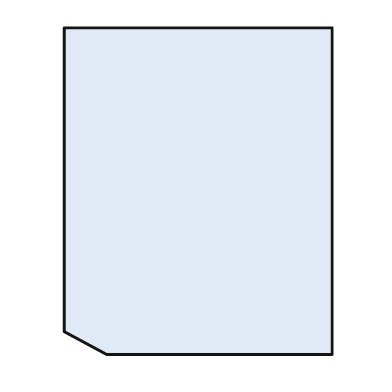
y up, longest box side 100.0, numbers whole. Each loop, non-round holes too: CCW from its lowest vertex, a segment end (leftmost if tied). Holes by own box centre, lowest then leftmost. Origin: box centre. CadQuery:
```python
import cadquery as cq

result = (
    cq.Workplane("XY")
    .moveTo(-28.0, -50.0)
    .lineTo(41.0, -50.0)
    .lineTo(41.0, 50.0)
    .lineTo(-41.0, 50.0)
    .lineTo(-41.0, -43.0)
    .close()
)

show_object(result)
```